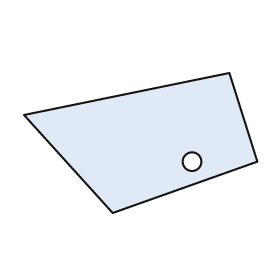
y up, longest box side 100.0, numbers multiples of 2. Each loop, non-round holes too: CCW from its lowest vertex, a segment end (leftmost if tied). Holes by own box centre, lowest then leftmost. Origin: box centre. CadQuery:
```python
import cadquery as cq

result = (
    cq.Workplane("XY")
    .moveTo(-12.0, -30.0)
    .lineTo(50.0, -8.0)
    .lineTo(38.0, 30.0)
    .lineTo(-50.0, 12.0)
    .close()
    .moveTo(22.0, -8.0)
    .circle(4.0)
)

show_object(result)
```